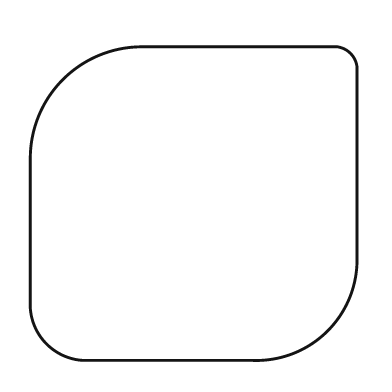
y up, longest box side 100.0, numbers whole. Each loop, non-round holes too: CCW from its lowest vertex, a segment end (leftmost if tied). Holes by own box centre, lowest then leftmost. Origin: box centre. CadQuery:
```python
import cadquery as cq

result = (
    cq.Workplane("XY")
    .moveTo(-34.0, -48.0)
    .lineTo(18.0, -48.0)
    .threePointArc((41.0, -39.0), (50.0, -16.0))
    .lineTo(50.0, 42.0)
    .threePointArc((48.0, 46.0), (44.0, 48.0))
    .lineTo(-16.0, 48.0)
    .threePointArc((-40.0, 38.0), (-50.0, 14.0))
    .lineTo(-50.0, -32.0)
    .threePointArc((-45.0, -43.0), (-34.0, -48.0))
    .close()
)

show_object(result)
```